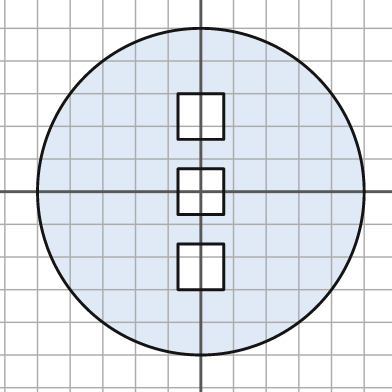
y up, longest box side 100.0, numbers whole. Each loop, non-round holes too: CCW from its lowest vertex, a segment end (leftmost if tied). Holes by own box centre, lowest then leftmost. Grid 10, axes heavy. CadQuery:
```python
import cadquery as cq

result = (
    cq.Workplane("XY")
    .moveTo(0.0, 0.0)
    .circle(50.0)
    .moveTo(-7.0, -30.0)
    .lineTo(7.0, -30.0)
    .lineTo(7.0, -16.0)
    .lineTo(-7.0, -16.0)
    .close()
    .moveTo(-7.0, -7.0)
    .lineTo(7.0, -7.0)
    .lineTo(7.0, 7.0)
    .lineTo(-7.0, 7.0)
    .close()
    .moveTo(-7.0, 16.0)
    .lineTo(7.0, 16.0)
    .lineTo(7.0, 30.0)
    .lineTo(-7.0, 30.0)
    .close()
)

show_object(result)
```